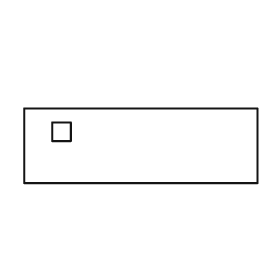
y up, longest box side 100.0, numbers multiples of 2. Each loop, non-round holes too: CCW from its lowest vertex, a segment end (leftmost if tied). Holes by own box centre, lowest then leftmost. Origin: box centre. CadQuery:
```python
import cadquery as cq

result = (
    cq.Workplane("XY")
    .moveTo(-50.0, -16.0)
    .lineTo(50.0, -16.0)
    .lineTo(50.0, 16.0)
    .lineTo(-50.0, 16.0)
    .close()
    .moveTo(-38.0, 2.0)
    .lineTo(-30.0, 2.0)
    .lineTo(-30.0, 10.0)
    .lineTo(-38.0, 10.0)
    .close()
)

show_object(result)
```